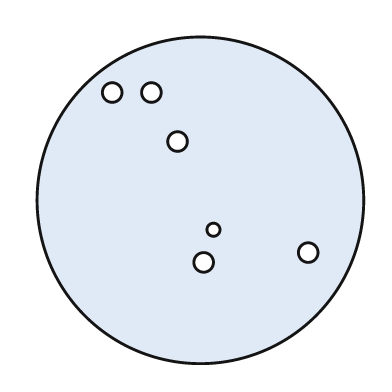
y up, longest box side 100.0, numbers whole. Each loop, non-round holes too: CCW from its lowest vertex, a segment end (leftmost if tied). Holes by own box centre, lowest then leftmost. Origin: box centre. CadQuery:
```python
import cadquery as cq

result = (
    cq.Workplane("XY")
    .moveTo(0.0, 0.0)
    .circle(50.0)
    .moveTo(1.0, -19.0)
    .circle(3.0)
    .moveTo(33.0, -16.0)
    .circle(3.0)
    .moveTo(4.0, -9.0)
    .circle(2.0)
    .moveTo(-7.0, 18.0)
    .circle(3.0)
    .moveTo(-27.0, 33.0)
    .circle(3.0)
    .moveTo(-15.0, 33.0)
    .circle(3.0)
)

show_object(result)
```